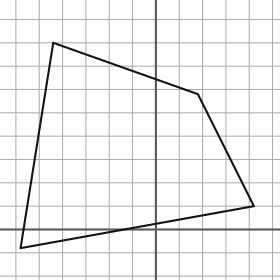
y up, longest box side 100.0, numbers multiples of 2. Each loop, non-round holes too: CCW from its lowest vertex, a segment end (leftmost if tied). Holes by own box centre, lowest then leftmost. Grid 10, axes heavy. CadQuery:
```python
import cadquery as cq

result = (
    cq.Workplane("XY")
    .moveTo(-58.0, -8.0)
    .lineTo(42.0, 10.0)
    .lineTo(18.0, 58.0)
    .lineTo(-44.0, 80.0)
    .close()
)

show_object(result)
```